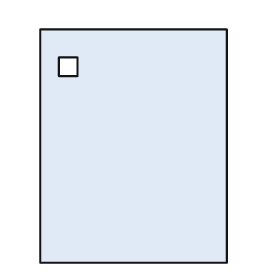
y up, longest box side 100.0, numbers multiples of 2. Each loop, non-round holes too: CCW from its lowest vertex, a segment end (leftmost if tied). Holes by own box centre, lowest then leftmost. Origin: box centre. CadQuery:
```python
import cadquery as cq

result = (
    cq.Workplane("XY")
    .moveTo(-40.0, -50.0)
    .lineTo(40.0, -50.0)
    .lineTo(40.0, 50.0)
    .lineTo(-40.0, 50.0)
    .close()
    .moveTo(-32.0, 30.0)
    .lineTo(-24.0, 30.0)
    .lineTo(-24.0, 38.0)
    .lineTo(-32.0, 38.0)
    .close()
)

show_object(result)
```